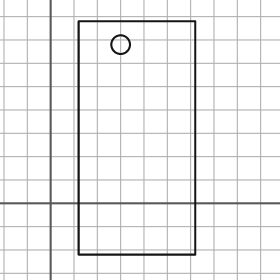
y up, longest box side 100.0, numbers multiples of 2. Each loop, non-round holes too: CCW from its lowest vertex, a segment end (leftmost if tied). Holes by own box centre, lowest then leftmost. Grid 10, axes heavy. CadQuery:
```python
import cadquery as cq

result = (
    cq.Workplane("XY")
    .moveTo(12.0, -22.0)
    .lineTo(62.0, -22.0)
    .lineTo(62.0, 78.0)
    .lineTo(12.0, 78.0)
    .close()
    .moveTo(30.0, 68.0)
    .circle(4.0)
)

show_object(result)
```